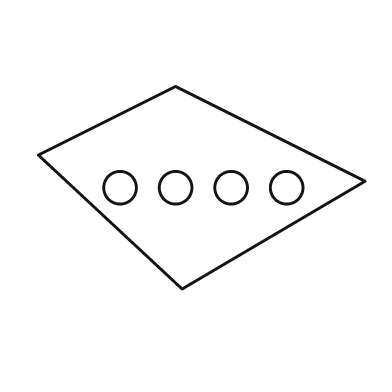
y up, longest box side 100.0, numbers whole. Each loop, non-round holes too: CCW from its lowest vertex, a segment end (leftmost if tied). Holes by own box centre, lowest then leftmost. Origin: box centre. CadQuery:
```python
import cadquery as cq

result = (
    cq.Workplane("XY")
    .moveTo(-6.0, -31.0)
    .lineTo(50.0, 2.0)
    .lineTo(-8.0, 31.0)
    .lineTo(-50.0, 10.0)
    .close()
    .moveTo(-25.0, 0.0)
    .circle(5.0)
    .moveTo(-8.0, 0.0)
    .circle(5.0)
    .moveTo(9.0, 0.0)
    .circle(5.0)
    .moveTo(26.0, 0.0)
    .circle(5.0)
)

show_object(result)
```